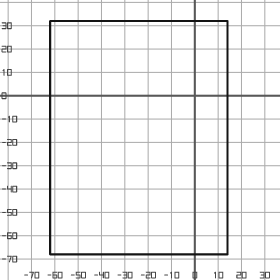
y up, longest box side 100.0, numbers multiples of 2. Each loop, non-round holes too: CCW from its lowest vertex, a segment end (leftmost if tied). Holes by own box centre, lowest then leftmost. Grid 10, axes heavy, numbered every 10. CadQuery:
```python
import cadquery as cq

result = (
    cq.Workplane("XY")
    .moveTo(-62.0, -68.0)
    .lineTo(14.0, -68.0)
    .lineTo(14.0, 32.0)
    .lineTo(-62.0, 32.0)
    .close()
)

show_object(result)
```